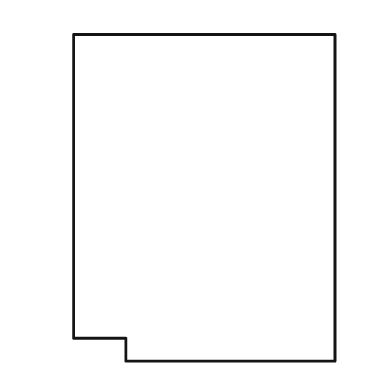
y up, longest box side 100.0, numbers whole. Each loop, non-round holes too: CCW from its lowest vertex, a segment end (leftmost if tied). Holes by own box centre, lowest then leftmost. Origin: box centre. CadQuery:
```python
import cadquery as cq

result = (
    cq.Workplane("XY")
    .moveTo(-24.0, -50.0)
    .lineTo(40.0, -50.0)
    .lineTo(40.0, 50.0)
    .lineTo(-40.0, 50.0)
    .lineTo(-40.0, -43.0)
    .lineTo(-24.0, -43.0)
    .close()
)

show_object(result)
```